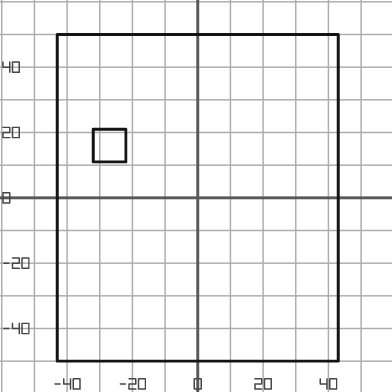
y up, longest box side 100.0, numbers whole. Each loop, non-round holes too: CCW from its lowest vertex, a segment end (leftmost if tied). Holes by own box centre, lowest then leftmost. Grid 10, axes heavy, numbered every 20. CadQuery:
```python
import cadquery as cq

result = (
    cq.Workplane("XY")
    .moveTo(-43.0, -50.0)
    .lineTo(43.0, -50.0)
    .lineTo(43.0, 50.0)
    .lineTo(-43.0, 50.0)
    .close()
    .moveTo(-32.0, 11.0)
    .lineTo(-22.0, 11.0)
    .lineTo(-22.0, 21.0)
    .lineTo(-32.0, 21.0)
    .close()
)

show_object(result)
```